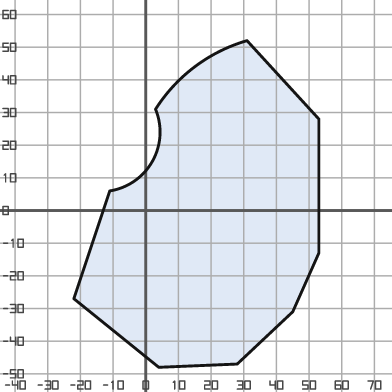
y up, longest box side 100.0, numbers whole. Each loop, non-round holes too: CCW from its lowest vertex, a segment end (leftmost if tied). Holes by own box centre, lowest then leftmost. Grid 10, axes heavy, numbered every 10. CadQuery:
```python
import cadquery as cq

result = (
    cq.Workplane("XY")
    .moveTo(4.0, -48.0)
    .lineTo(28.0, -47.0)
    .lineTo(45.0, -31.0)
    .lineTo(53.0, -13.0)
    .lineTo(53.0, 28.0)
    .lineTo(31.0, 52.0)
    .threePointArc((15.0, 44.0), (3.0, 31.0))
    .threePointArc((2.0, 15.0), (-11.0, 6.0))
    .lineTo(-22.0, -27.0)
    .close()
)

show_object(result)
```